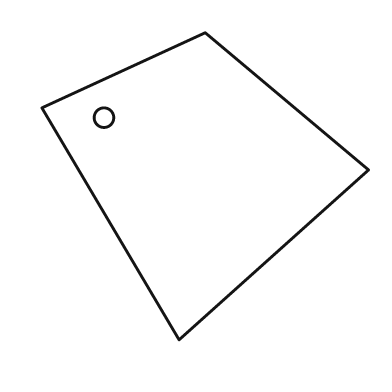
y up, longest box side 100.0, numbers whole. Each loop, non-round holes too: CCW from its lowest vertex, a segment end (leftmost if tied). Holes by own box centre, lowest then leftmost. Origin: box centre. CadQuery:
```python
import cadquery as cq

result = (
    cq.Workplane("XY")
    .moveTo(-8.0, -47.0)
    .lineTo(50.0, 5.0)
    .lineTo(0.0, 47.0)
    .lineTo(-50.0, 24.0)
    .close()
    .moveTo(-31.0, 21.0)
    .circle(3.0)
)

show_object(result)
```